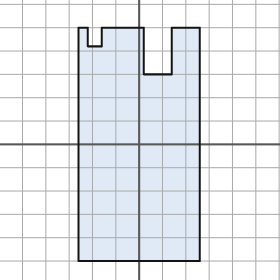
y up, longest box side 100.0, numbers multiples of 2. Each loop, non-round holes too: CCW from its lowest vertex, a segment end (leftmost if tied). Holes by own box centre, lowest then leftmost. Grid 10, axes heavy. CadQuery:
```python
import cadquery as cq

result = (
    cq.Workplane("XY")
    .moveTo(-26.0, -50.0)
    .lineTo(26.0, -50.0)
    .lineTo(26.0, 50.0)
    .lineTo(14.0, 50.0)
    .lineTo(14.0, 30.0)
    .lineTo(2.0, 30.0)
    .lineTo(2.0, 50.0)
    .lineTo(-16.0, 50.0)
    .lineTo(-16.0, 42.0)
    .lineTo(-22.0, 42.0)
    .lineTo(-22.0, 50.0)
    .lineTo(-26.0, 50.0)
    .close()
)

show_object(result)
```